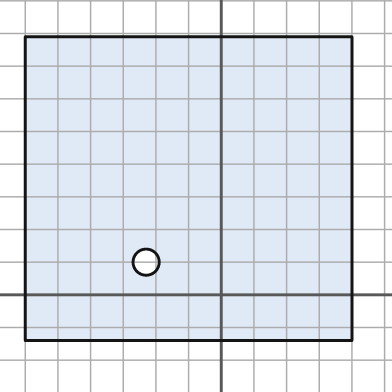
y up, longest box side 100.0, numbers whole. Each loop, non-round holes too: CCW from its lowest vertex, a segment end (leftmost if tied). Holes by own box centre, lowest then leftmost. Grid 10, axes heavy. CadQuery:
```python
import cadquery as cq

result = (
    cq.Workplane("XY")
    .moveTo(-60.0, -14.0)
    .lineTo(40.0, -14.0)
    .lineTo(40.0, 79.0)
    .lineTo(-60.0, 79.0)
    .close()
    .moveTo(-23.0, 10.0)
    .circle(4.0)
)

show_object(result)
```